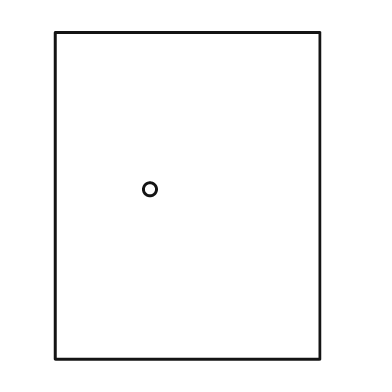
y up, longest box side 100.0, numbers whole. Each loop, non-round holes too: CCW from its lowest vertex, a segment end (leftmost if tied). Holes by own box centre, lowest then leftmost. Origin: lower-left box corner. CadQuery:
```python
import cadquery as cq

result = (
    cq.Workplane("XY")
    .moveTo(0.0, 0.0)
    .lineTo(81.0, 0.0)
    .lineTo(81.0, 100.0)
    .lineTo(0.0, 100.0)
    .close()
    .moveTo(29.0, 52.0)
    .circle(2.0)
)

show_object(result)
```